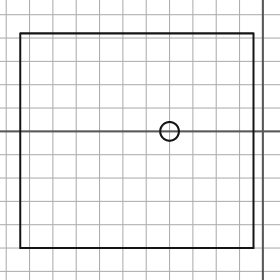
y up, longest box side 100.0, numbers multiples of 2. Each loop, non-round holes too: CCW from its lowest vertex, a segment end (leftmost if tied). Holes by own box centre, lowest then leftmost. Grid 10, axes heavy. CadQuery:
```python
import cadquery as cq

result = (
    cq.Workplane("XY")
    .moveTo(-104.0, -50.0)
    .lineTo(-4.0, -50.0)
    .lineTo(-4.0, 42.0)
    .lineTo(-104.0, 42.0)
    .close()
    .moveTo(-40.0, 0.0)
    .circle(4.0)
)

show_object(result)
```